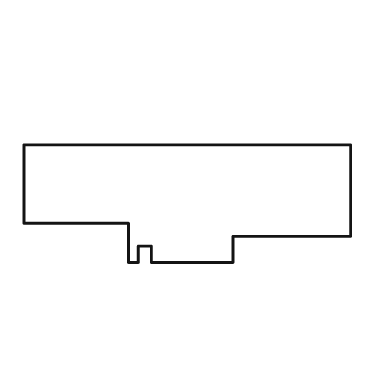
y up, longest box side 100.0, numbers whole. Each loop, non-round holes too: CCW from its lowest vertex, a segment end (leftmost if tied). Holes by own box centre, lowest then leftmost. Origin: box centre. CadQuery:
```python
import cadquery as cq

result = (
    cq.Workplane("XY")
    .moveTo(-18.0, -18.0)
    .lineTo(-15.0, -18.0)
    .lineTo(-15.0, -13.0)
    .lineTo(-11.0, -13.0)
    .lineTo(-11.0, -18.0)
    .lineTo(14.0, -18.0)
    .lineTo(14.0, -10.0)
    .lineTo(50.0, -10.0)
    .lineTo(50.0, 18.0)
    .lineTo(-50.0, 18.0)
    .lineTo(-50.0, -6.0)
    .lineTo(-18.0, -6.0)
    .close()
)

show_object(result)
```